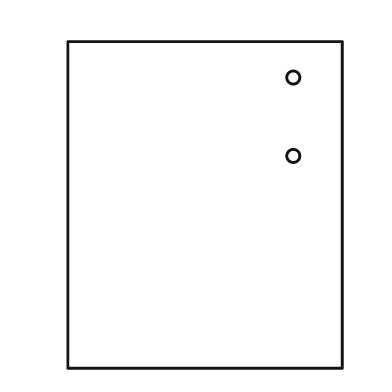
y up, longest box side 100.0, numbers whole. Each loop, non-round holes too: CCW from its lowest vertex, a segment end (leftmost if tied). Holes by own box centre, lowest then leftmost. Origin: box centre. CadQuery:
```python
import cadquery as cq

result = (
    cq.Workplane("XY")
    .moveTo(-42.0, -50.0)
    .lineTo(42.0, -50.0)
    .lineTo(42.0, 50.0)
    .lineTo(-42.0, 50.0)
    .close()
    .moveTo(27.0, 15.0)
    .circle(2.0)
    .moveTo(27.0, 39.0)
    .circle(2.0)
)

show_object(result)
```